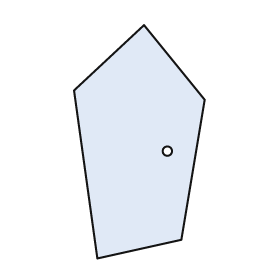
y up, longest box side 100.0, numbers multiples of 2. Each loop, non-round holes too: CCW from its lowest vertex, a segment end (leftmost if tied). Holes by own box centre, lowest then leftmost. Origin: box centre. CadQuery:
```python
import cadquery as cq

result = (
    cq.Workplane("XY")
    .moveTo(-18.0, -50.0)
    .lineTo(18.0, -42.0)
    .lineTo(28.0, 18.0)
    .lineTo(2.0, 50.0)
    .lineTo(-28.0, 22.0)
    .close()
    .moveTo(12.0, -4.0)
    .circle(2.0)
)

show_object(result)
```